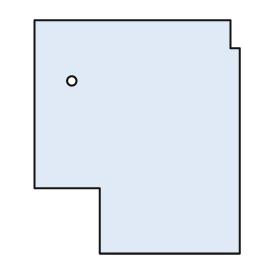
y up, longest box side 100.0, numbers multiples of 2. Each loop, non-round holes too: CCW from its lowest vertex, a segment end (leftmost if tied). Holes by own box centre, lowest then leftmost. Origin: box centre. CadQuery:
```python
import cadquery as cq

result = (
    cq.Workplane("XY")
    .moveTo(-16.0, -50.0)
    .lineTo(44.0, -50.0)
    .lineTo(44.0, 38.0)
    .lineTo(40.0, 38.0)
    .lineTo(40.0, 50.0)
    .lineTo(-44.0, 50.0)
    .lineTo(-44.0, -22.0)
    .lineTo(-16.0, -22.0)
    .close()
    .moveTo(-28.0, 24.0)
    .circle(2.0)
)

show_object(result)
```